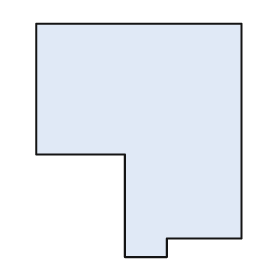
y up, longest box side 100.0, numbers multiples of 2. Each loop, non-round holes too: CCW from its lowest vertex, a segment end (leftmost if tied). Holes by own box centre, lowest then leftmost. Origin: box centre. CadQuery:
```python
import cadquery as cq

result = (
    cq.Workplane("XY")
    .moveTo(-6.0, -50.0)
    .lineTo(12.0, -50.0)
    .lineTo(12.0, -42.0)
    .lineTo(44.0, -42.0)
    .lineTo(44.0, 50.0)
    .lineTo(-44.0, 50.0)
    .lineTo(-44.0, -6.0)
    .lineTo(-6.0, -6.0)
    .close()
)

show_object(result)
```